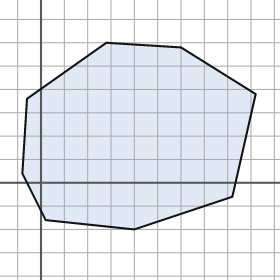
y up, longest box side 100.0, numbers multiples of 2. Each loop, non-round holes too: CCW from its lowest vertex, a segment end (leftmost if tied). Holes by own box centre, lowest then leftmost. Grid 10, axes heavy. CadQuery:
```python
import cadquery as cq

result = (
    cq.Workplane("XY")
    .moveTo(40.0, -20.0)
    .lineTo(82.0, -6.0)
    .lineTo(92.0, 38.0)
    .lineTo(60.0, 58.0)
    .lineTo(28.0, 60.0)
    .lineTo(-6.0, 36.0)
    .lineTo(-8.0, 4.0)
    .lineTo(2.0, -16.0)
    .close()
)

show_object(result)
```